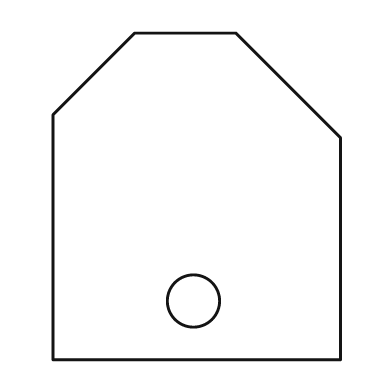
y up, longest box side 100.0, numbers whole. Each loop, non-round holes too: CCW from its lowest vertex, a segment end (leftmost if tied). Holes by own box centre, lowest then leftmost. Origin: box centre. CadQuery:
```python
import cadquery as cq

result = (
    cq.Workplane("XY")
    .moveTo(-44.0, -50.0)
    .lineTo(44.0, -50.0)
    .lineTo(44.0, 18.0)
    .lineTo(12.0, 50.0)
    .lineTo(-19.0, 50.0)
    .lineTo(-44.0, 25.0)
    .close()
    .moveTo(-1.0, -32.0)
    .circle(8.0)
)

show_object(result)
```